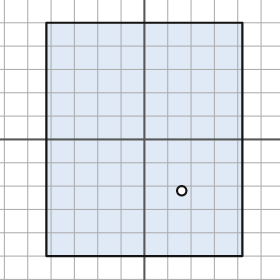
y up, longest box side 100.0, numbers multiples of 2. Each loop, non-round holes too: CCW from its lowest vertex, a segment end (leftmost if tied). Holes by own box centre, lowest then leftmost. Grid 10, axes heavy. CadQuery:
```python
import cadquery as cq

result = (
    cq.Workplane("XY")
    .moveTo(-42.0, -50.0)
    .lineTo(42.0, -50.0)
    .lineTo(42.0, 50.0)
    .lineTo(-42.0, 50.0)
    .close()
    .moveTo(16.0, -22.0)
    .circle(2.0)
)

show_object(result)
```